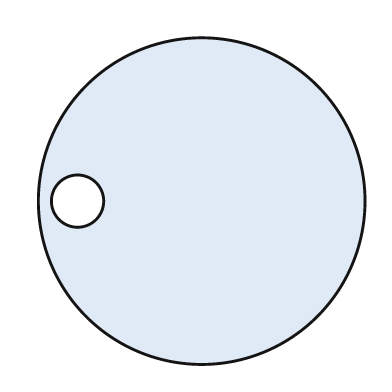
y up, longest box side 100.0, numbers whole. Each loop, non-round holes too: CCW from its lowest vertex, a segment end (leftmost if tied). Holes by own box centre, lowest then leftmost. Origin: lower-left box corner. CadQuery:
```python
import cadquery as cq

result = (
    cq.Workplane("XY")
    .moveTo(50.0, 50.0)
    .circle(50.0)
    .moveTo(12.0, 50.0)
    .circle(8.0)
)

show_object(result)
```